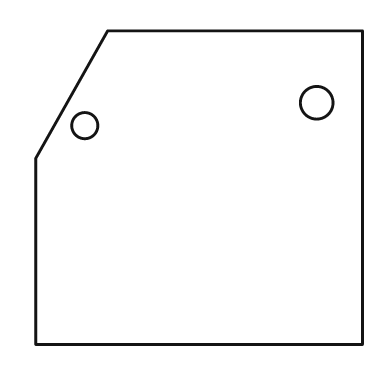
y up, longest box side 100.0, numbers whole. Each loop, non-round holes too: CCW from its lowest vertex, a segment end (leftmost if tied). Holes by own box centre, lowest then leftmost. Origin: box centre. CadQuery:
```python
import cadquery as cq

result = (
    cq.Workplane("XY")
    .moveTo(-50.0, -48.0)
    .lineTo(50.0, -48.0)
    .lineTo(50.0, 48.0)
    .lineTo(-28.0, 48.0)
    .lineTo(-50.0, 9.0)
    .close()
    .moveTo(-35.0, 19.0)
    .circle(4.0)
    .moveTo(36.0, 26.0)
    .circle(5.0)
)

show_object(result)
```